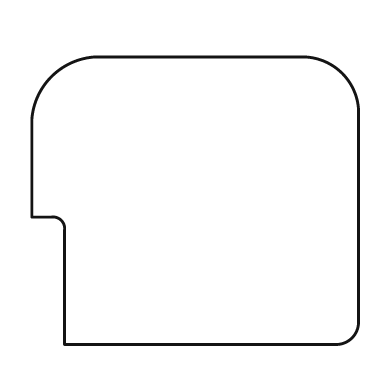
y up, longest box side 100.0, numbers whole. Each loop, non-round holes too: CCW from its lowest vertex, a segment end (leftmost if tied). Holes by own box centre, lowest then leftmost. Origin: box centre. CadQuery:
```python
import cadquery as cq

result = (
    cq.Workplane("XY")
    .moveTo(-40.0, -44.0)
    .lineTo(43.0, -44.0)
    .threePointArc((48.0, -42.0), (50.0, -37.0))
    .lineTo(50.0, 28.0)
    .threePointArc((45.0, 39.0), (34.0, 44.0))
    .lineTo(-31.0, 44.0)
    .threePointArc((-44.0, 38.0), (-50.0, 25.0))
    .lineTo(-50.0, -5.0)
    .lineTo(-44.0, -5.0)
    .threePointArc((-41.0, -6.0), (-40.0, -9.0))
    .close()
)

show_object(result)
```